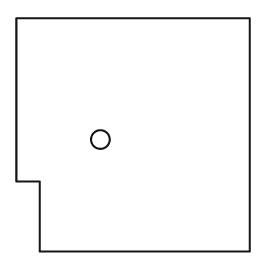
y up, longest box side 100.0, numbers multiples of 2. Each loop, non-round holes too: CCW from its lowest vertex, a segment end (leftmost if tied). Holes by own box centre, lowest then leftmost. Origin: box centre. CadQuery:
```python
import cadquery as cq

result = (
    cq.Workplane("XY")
    .moveTo(-40.0, -50.0)
    .lineTo(50.0, -50.0)
    .lineTo(50.0, 50.0)
    .lineTo(-50.0, 50.0)
    .lineTo(-50.0, -20.0)
    .lineTo(-40.0, -20.0)
    .close()
    .moveTo(-14.0, -2.0)
    .circle(4.0)
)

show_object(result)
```